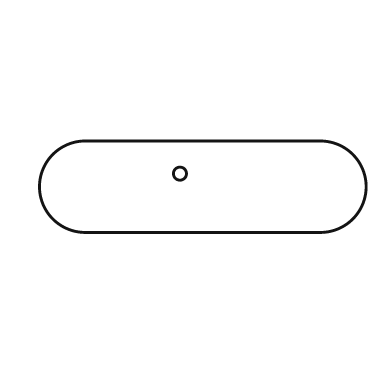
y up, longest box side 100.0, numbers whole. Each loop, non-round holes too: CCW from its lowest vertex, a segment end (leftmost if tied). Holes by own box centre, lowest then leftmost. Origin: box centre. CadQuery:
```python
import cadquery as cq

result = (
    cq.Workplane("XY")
    .moveTo(-36.0, -14.0)
    .lineTo(36.0, -14.0)
    .threePointArc((50.0, 0.0), (36.0, 14.0))
    .lineTo(-36.0, 14.0)
    .threePointArc((-50.0, 0.0), (-36.0, -14.0))
    .close()
    .moveTo(-7.0, 4.0)
    .circle(2.0)
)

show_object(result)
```